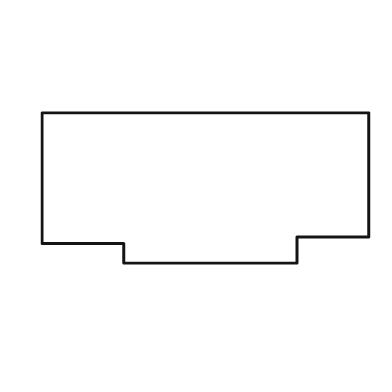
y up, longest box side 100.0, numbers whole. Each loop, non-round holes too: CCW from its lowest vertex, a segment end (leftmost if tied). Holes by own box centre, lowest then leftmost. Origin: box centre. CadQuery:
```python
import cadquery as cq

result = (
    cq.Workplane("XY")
    .moveTo(-25.0, -23.0)
    .lineTo(28.0, -23.0)
    .lineTo(28.0, -15.0)
    .lineTo(50.0, -15.0)
    .lineTo(50.0, 23.0)
    .lineTo(-50.0, 23.0)
    .lineTo(-50.0, -17.0)
    .lineTo(-25.0, -17.0)
    .close()
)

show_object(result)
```